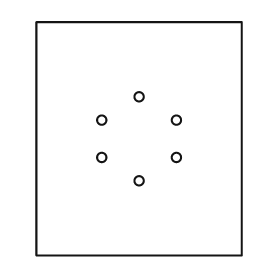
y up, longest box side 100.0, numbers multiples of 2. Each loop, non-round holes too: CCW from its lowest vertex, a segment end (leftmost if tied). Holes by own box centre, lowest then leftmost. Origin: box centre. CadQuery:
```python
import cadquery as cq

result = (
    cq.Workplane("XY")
    .moveTo(-44.0, -50.0)
    .lineTo(44.0, -50.0)
    .lineTo(44.0, 50.0)
    .lineTo(-44.0, 50.0)
    .close()
    .moveTo(0.0, -18.0)
    .circle(2.0)
    .moveTo(-16.0, -8.0)
    .circle(2.0)
    .moveTo(16.0, -8.0)
    .circle(2.0)
    .moveTo(-16.0, 8.0)
    .circle(2.0)
    .moveTo(16.0, 8.0)
    .circle(2.0)
    .moveTo(0.0, 18.0)
    .circle(2.0)
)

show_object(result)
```